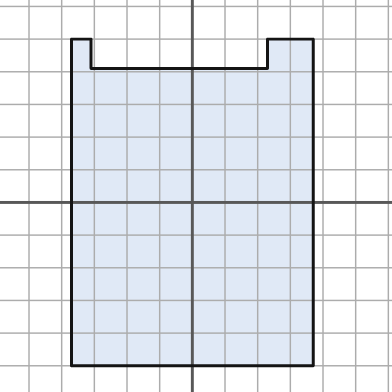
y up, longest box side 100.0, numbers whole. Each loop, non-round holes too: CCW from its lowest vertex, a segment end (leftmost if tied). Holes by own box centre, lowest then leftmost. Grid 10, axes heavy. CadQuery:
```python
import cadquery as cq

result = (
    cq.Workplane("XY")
    .moveTo(-37.0, -50.0)
    .lineTo(37.0, -50.0)
    .lineTo(37.0, 50.0)
    .lineTo(23.0, 50.0)
    .lineTo(23.0, 41.0)
    .lineTo(-31.0, 41.0)
    .lineTo(-31.0, 50.0)
    .lineTo(-37.0, 50.0)
    .close()
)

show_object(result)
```